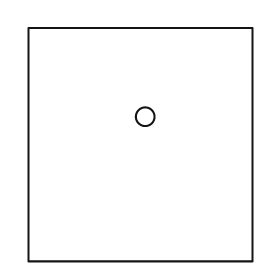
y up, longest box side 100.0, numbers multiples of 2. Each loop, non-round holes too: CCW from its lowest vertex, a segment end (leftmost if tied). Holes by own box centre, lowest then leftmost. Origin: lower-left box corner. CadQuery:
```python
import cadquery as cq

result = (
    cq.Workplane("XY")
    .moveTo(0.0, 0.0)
    .lineTo(96.0, 0.0)
    .lineTo(96.0, 100.0)
    .lineTo(0.0, 100.0)
    .close()
    .moveTo(50.0, 62.0)
    .circle(4.0)
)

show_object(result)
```